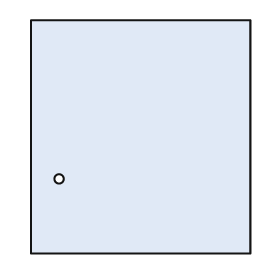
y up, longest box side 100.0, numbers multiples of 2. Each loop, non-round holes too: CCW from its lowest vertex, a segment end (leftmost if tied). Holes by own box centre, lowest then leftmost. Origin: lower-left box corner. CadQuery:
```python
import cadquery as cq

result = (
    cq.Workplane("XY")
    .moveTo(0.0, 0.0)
    .lineTo(94.0, 0.0)
    .lineTo(94.0, 100.0)
    .lineTo(0.0, 100.0)
    .close()
    .moveTo(12.0, 32.0)
    .circle(2.0)
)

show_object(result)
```